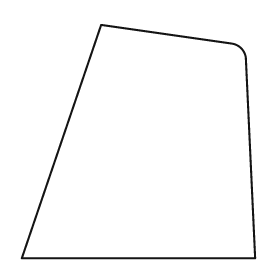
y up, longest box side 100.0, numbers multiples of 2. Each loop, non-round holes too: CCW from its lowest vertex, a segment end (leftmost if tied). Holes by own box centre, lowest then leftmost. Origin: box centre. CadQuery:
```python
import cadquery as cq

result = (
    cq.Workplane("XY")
    .moveTo(-50.0, -50.0)
    .lineTo(50.0, -50.0)
    .lineTo(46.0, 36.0)
    .threePointArc((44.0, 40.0), (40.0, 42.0))
    .lineTo(-16.0, 50.0)
    .close()
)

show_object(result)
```